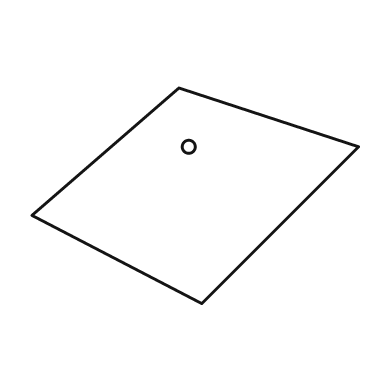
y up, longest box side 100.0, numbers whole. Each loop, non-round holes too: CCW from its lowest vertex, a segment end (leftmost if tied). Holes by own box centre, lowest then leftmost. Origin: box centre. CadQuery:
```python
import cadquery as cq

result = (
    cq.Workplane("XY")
    .moveTo(2.0, -33.0)
    .lineTo(50.0, 15.0)
    .lineTo(-5.0, 33.0)
    .lineTo(-50.0, -6.0)
    .close()
    .moveTo(-2.0, 15.0)
    .circle(2.0)
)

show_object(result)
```